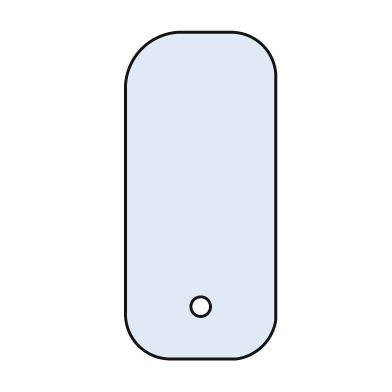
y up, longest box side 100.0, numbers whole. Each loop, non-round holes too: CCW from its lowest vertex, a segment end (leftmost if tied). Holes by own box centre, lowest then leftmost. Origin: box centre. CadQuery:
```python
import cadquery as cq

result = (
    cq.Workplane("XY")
    .moveTo(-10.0, -50.0)
    .lineTo(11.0, -50.0)
    .threePointArc((19.0, -46.0), (23.0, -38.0))
    .lineTo(23.0, 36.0)
    .threePointArc((19.0, 46.0), (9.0, 50.0))
    .lineTo(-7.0, 50.0)
    .threePointArc((-18.0, 45.0), (-23.0, 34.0))
    .lineTo(-23.0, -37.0)
    .threePointArc((-19.0, -46.0), (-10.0, -50.0))
    .close()
    .moveTo(0.0, -34.0)
    .circle(3.0)
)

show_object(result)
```